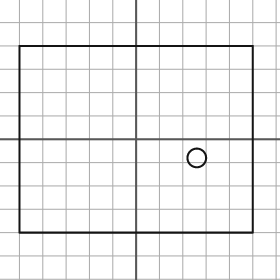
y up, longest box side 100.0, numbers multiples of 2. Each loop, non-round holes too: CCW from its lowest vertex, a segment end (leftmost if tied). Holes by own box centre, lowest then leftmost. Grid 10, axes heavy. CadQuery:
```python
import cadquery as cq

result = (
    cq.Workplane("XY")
    .moveTo(-50.0, -40.0)
    .lineTo(50.0, -40.0)
    .lineTo(50.0, 40.0)
    .lineTo(-50.0, 40.0)
    .close()
    .moveTo(26.0, -8.0)
    .circle(4.0)
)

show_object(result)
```